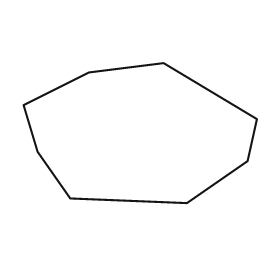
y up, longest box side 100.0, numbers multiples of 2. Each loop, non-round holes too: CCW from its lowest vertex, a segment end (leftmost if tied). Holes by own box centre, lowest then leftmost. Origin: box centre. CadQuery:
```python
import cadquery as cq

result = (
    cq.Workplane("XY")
    .moveTo(20.0, -30.0)
    .lineTo(46.0, -12.0)
    .lineTo(50.0, 6.0)
    .lineTo(10.0, 30.0)
    .lineTo(-22.0, 26.0)
    .lineTo(-50.0, 12.0)
    .lineTo(-44.0, -8.0)
    .lineTo(-30.0, -28.0)
    .close()
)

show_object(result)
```